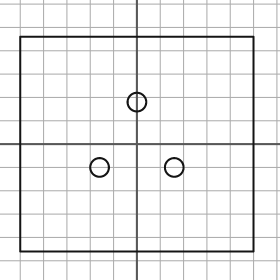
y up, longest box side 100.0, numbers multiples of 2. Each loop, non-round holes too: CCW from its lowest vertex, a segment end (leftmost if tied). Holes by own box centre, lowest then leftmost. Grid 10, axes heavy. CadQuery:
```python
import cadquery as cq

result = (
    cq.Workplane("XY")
    .moveTo(-50.0, -46.0)
    .lineTo(50.0, -46.0)
    .lineTo(50.0, 46.0)
    .lineTo(-50.0, 46.0)
    .close()
    .moveTo(-16.0, -10.0)
    .circle(4.0)
    .moveTo(16.0, -10.0)
    .circle(4.0)
    .moveTo(0.0, 18.0)
    .circle(4.0)
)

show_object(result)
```